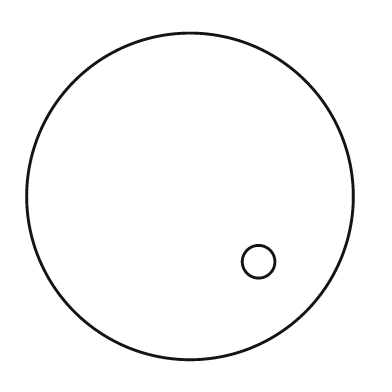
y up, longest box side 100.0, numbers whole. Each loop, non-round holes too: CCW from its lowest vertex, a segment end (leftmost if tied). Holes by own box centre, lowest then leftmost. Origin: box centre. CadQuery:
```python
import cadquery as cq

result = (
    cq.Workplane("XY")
    .moveTo(0.0, 0.0)
    .circle(50.0)
    .moveTo(21.0, -20.0)
    .circle(5.0)
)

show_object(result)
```